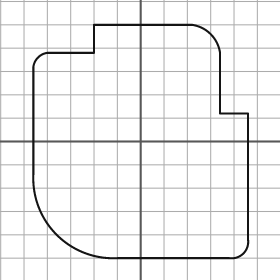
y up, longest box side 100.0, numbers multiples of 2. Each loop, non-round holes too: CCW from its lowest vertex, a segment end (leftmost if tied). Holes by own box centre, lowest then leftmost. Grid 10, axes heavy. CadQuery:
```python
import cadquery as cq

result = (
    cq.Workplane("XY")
    .moveTo(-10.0, -50.0)
    .lineTo(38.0, -50.0)
    .threePointArc((44.0, -48.0), (46.0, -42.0))
    .lineTo(46.0, 12.0)
    .lineTo(34.0, 12.0)
    .lineTo(34.0, 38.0)
    .threePointArc((30.0, 46.0), (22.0, 50.0))
    .lineTo(-20.0, 50.0)
    .lineTo(-20.0, 38.0)
    .lineTo(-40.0, 38.0)
    .threePointArc((-44.0, 36.0), (-46.0, 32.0))
    .lineTo(-46.0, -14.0)
    .threePointArc((-36.0, -40.0), (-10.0, -50.0))
    .close()
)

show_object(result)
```